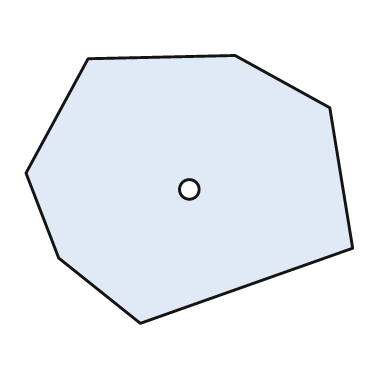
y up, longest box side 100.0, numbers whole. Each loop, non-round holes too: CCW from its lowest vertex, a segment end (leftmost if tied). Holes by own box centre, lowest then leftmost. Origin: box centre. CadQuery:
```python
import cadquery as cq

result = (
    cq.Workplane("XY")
    .moveTo(-15.0, -41.0)
    .lineTo(50.0, -18.0)
    .lineTo(43.0, 25.0)
    .lineTo(14.0, 41.0)
    .lineTo(-31.0, 40.0)
    .lineTo(-50.0, 5.0)
    .lineTo(-40.0, -21.0)
    .close()
    .moveTo(0.0, 0.0)
    .circle(3.0)
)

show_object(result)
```